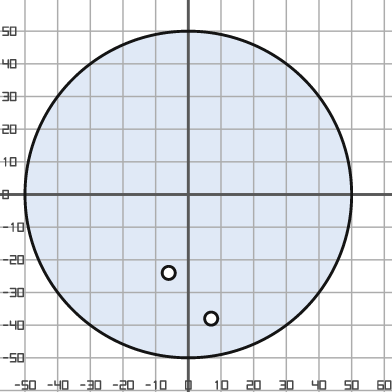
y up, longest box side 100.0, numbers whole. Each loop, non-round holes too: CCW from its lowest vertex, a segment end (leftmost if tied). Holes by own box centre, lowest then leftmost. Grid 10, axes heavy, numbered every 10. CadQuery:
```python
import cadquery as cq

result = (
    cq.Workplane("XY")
    .moveTo(0.0, 0.0)
    .circle(50.0)
    .moveTo(7.0, -38.0)
    .circle(2.0)
    .moveTo(-6.0, -24.0)
    .circle(2.0)
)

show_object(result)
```